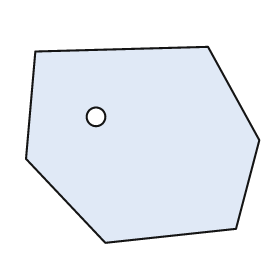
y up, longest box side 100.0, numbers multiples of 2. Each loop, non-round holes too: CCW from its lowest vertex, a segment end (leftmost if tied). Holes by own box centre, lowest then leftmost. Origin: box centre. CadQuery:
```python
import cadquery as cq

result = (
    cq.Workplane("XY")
    .moveTo(-16.0, -42.0)
    .lineTo(40.0, -36.0)
    .lineTo(50.0, 2.0)
    .lineTo(28.0, 42.0)
    .lineTo(-46.0, 40.0)
    .lineTo(-50.0, -6.0)
    .close()
    .moveTo(-20.0, 12.0)
    .circle(4.0)
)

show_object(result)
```